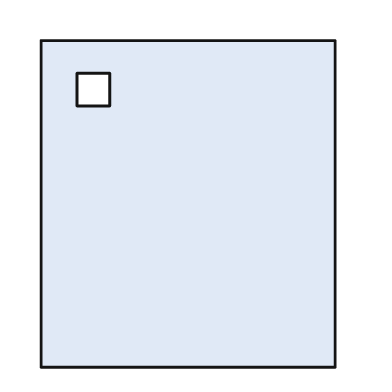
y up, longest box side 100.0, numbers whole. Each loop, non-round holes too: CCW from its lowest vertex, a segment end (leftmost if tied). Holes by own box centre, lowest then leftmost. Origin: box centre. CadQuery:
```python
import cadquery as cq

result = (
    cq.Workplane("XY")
    .moveTo(-45.0, -50.0)
    .lineTo(45.0, -50.0)
    .lineTo(45.0, 50.0)
    .lineTo(-45.0, 50.0)
    .close()
    .moveTo(-34.0, 30.0)
    .lineTo(-24.0, 30.0)
    .lineTo(-24.0, 40.0)
    .lineTo(-34.0, 40.0)
    .close()
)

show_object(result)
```